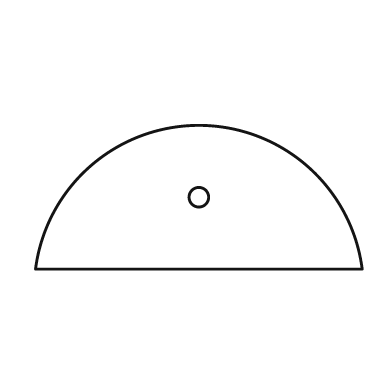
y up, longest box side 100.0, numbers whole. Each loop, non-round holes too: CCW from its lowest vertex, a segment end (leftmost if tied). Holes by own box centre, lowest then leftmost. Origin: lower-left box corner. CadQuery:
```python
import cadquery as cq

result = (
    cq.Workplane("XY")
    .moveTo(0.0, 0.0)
    .lineTo(100.0, 0.0)
    .threePointArc((50.0, 44.0), (0.0, 0.0))
    .close()
    .moveTo(50.0, 22.0)
    .circle(3.0)
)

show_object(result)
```